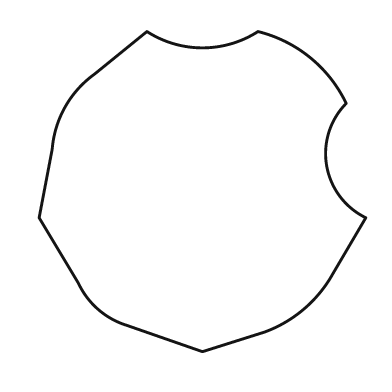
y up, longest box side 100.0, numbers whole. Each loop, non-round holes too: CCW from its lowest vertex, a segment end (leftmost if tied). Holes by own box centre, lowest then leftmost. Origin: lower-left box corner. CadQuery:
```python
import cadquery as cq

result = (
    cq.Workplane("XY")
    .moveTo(50.0, 0.0)
    .lineTo(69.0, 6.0)
    .threePointArc((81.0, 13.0), (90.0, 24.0))
    .lineTo(100.0, 41.0)
    .threePointArc((88.0, 57.0), (94.0, 76.0))
    .threePointArc((83.0, 90.0), (67.0, 98.0))
    .threePointArc((50.0, 93.0), (33.0, 98.0))
    .lineTo(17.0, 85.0)
    .threePointArc((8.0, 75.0), (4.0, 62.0))
    .lineTo(0.0, 41.0)
    .lineTo(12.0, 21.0)
    .threePointArc((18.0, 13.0), (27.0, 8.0))
    .close()
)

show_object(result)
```